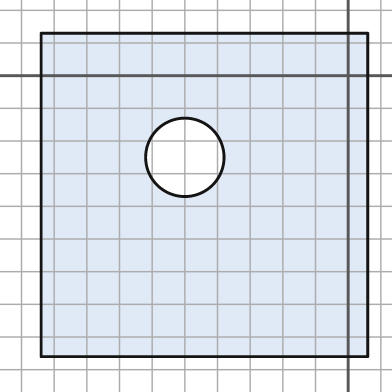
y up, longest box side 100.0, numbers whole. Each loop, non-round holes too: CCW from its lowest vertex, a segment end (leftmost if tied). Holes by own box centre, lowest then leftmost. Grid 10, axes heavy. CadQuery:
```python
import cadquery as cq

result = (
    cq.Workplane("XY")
    .moveTo(-94.0, -86.0)
    .lineTo(6.0, -86.0)
    .lineTo(6.0, 13.0)
    .lineTo(-94.0, 13.0)
    .close()
    .moveTo(-50.0, -25.0)
    .circle(12.0)
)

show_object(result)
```